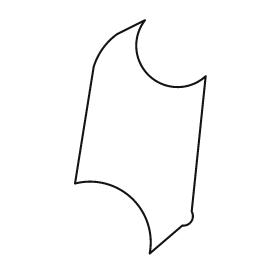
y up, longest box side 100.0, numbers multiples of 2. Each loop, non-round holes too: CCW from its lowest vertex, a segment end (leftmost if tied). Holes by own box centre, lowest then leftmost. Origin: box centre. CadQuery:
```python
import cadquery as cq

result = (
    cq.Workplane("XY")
    .moveTo(4.0, -50.0)
    .lineTo(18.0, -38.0)
    .threePointArc((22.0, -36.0), (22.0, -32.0))
    .lineTo(28.0, 26.0)
    .threePointArc((4.0, 26.0), (2.0, 50.0))
    .lineTo(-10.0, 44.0)
    .threePointArc((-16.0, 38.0), (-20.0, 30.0))
    .lineTo(-28.0, -20.0)
    .threePointArc((-4.0, -26.0), (4.0, -50.0))
    .close()
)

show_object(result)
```